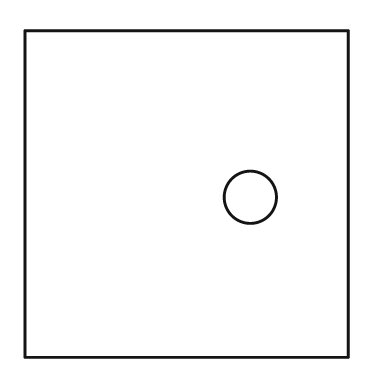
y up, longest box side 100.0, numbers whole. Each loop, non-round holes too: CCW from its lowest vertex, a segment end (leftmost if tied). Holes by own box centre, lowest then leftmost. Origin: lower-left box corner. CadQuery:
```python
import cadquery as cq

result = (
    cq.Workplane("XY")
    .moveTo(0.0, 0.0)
    .lineTo(99.0, 0.0)
    .lineTo(99.0, 100.0)
    .lineTo(0.0, 100.0)
    .close()
    .moveTo(69.0, 49.0)
    .circle(8.0)
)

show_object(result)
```